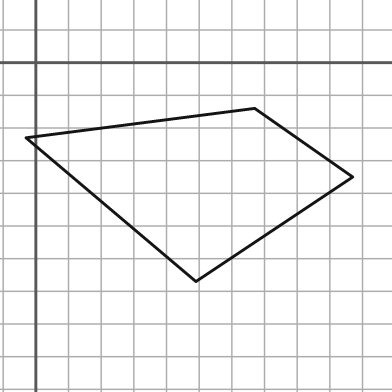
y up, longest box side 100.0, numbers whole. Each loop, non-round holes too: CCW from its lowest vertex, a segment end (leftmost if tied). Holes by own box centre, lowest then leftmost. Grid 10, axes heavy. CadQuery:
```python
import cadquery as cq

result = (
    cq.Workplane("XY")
    .moveTo(49.0, -67.0)
    .lineTo(97.0, -35.0)
    .lineTo(67.0, -14.0)
    .lineTo(-3.0, -23.0)
    .close()
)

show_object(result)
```